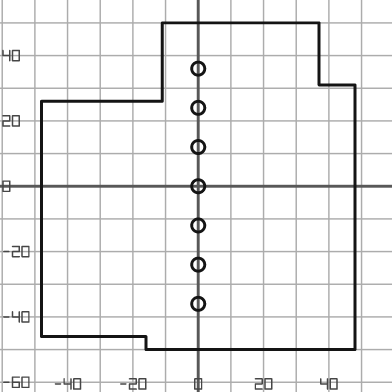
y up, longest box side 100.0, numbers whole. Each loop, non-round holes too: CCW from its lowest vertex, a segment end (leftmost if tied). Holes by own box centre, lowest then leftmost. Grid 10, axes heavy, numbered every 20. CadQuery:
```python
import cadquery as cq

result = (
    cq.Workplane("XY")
    .moveTo(-16.0, -50.0)
    .lineTo(48.0, -50.0)
    .lineTo(48.0, 31.0)
    .lineTo(37.0, 31.0)
    .lineTo(37.0, 50.0)
    .lineTo(-11.0, 50.0)
    .lineTo(-11.0, 26.0)
    .lineTo(-48.0, 26.0)
    .lineTo(-48.0, -46.0)
    .lineTo(-16.0, -46.0)
    .close()
    .moveTo(0.0, -36.0)
    .circle(2.0)
    .moveTo(0.0, -24.0)
    .circle(2.0)
    .moveTo(0.0, -12.0)
    .circle(2.0)
    .moveTo(0.0, 0.0)
    .circle(2.0)
    .moveTo(0.0, 12.0)
    .circle(2.0)
    .moveTo(0.0, 24.0)
    .circle(2.0)
    .moveTo(0.0, 36.0)
    .circle(2.0)
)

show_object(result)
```